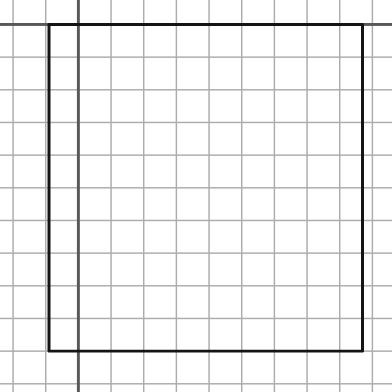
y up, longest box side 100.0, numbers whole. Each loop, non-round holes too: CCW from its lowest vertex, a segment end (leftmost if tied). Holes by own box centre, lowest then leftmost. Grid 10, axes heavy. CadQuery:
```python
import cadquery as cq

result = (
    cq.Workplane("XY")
    .moveTo(-9.0, -100.0)
    .lineTo(87.0, -100.0)
    .lineTo(87.0, 0.0)
    .lineTo(-9.0, 0.0)
    .close()
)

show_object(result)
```